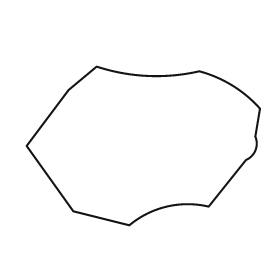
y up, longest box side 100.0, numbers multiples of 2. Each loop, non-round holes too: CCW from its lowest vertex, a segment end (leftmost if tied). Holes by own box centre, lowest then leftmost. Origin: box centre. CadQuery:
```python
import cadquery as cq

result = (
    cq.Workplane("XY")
    .moveTo(-6.0, -34.0)
    .threePointArc((10.0, -26.0), (28.0, -26.0))
    .lineTo(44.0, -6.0)
    .threePointArc((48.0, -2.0), (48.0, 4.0))
    .lineTo(50.0, 16.0)
    .threePointArc((38.0, 26.0), (24.0, 32.0))
    .threePointArc((2.0, 30.0), (-20.0, 34.0))
    .lineTo(-32.0, 24.0)
    .lineTo(-50.0, 0.0)
    .lineTo(-30.0, -28.0)
    .close()
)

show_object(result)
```